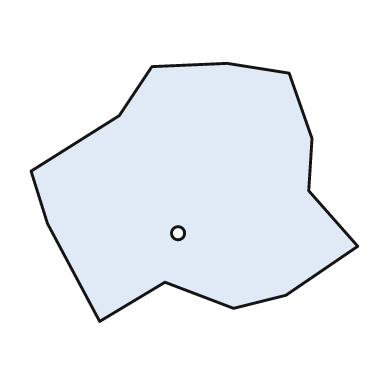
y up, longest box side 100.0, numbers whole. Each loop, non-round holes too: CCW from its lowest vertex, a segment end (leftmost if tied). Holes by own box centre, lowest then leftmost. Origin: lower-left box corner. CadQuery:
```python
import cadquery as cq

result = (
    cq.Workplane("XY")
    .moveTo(21.0, 0.0)
    .lineTo(41.0, 12.0)
    .lineTo(62.0, 4.0)
    .lineTo(78.0, 8.0)
    .lineTo(100.0, 23.0)
    .lineTo(85.0, 40.0)
    .lineTo(86.0, 56.0)
    .lineTo(79.0, 76.0)
    .lineTo(60.0, 79.0)
    .lineTo(37.0, 78.0)
    .lineTo(27.0, 63.0)
    .lineTo(0.0, 46.0)
    .lineTo(5.0, 30.0)
    .close()
    .moveTo(45.0, 27.0)
    .circle(2.0)
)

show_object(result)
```